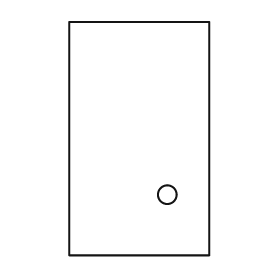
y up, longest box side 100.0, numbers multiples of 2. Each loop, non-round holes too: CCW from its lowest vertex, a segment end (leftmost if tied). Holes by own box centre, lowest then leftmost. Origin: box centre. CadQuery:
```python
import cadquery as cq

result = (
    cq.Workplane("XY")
    .moveTo(-30.0, -50.0)
    .lineTo(30.0, -50.0)
    .lineTo(30.0, 50.0)
    .lineTo(-30.0, 50.0)
    .close()
    .moveTo(12.0, -24.0)
    .circle(4.0)
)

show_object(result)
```